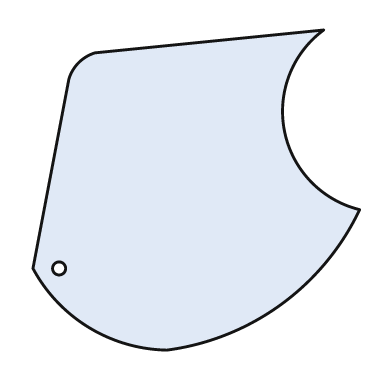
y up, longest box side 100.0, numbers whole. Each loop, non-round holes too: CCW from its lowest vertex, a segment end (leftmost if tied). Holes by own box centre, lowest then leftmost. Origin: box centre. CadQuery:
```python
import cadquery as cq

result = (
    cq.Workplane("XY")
    .moveTo(-9.0, -49.0)
    .threePointArc((26.0, -35.0), (50.0, -6.0))
    .threePointArc((27.0, 18.0), (39.0, 49.0))
    .lineTo(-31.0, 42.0)
    .threePointArc((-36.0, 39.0), (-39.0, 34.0))
    .lineTo(-50.0, -24.0)
    .threePointArc((-33.0, -42.0), (-9.0, -49.0))
    .close()
    .moveTo(-42.0, -24.0)
    .circle(2.0)
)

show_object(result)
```